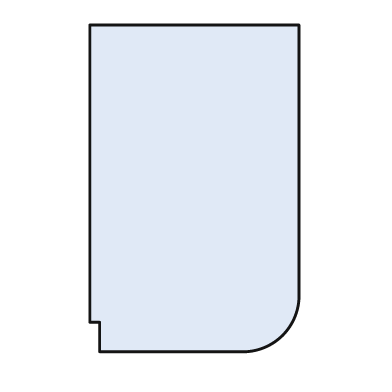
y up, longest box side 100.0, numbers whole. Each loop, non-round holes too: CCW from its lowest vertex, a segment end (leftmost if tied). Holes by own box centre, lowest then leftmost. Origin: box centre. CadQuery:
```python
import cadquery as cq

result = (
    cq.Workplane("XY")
    .moveTo(-29.0, -50.0)
    .lineTo(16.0, -50.0)
    .threePointArc((27.0, -45.0), (32.0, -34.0))
    .lineTo(32.0, 50.0)
    .lineTo(-32.0, 50.0)
    .lineTo(-32.0, -41.0)
    .lineTo(-29.0, -41.0)
    .close()
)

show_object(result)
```